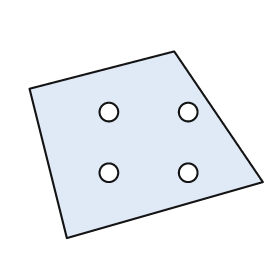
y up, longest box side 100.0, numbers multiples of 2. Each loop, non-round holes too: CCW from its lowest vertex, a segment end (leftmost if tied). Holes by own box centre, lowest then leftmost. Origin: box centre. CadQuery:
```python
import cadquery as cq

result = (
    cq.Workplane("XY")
    .moveTo(-34.0, -40.0)
    .lineTo(50.0, -16.0)
    .lineTo(12.0, 40.0)
    .lineTo(-50.0, 24.0)
    .close()
    .moveTo(-16.0, -12.0)
    .circle(4.0)
    .moveTo(18.0, -12.0)
    .circle(4.0)
    .moveTo(-16.0, 14.0)
    .circle(4.0)
    .moveTo(18.0, 14.0)
    .circle(4.0)
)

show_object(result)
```